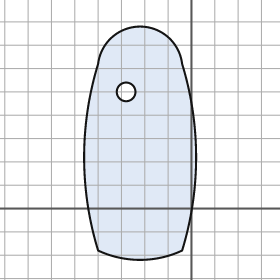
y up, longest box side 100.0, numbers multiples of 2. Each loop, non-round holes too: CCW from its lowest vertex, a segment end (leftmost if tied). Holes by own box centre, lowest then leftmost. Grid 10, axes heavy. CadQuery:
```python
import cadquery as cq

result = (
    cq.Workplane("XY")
    .moveTo(-40.0, -18.0)
    .threePointArc((-22.0, -22.0), (-4.0, -18.0))
    .threePointArc((2.0, 22.0), (-4.0, 62.0))
    .threePointArc((-22.0, 78.0), (-40.0, 62.0))
    .threePointArc((-46.0, 22.0), (-40.0, -18.0))
    .close()
    .moveTo(-28.0, 50.0)
    .circle(4.0)
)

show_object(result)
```